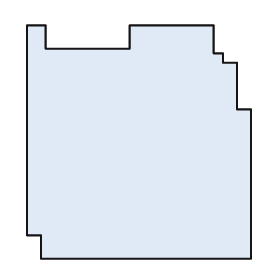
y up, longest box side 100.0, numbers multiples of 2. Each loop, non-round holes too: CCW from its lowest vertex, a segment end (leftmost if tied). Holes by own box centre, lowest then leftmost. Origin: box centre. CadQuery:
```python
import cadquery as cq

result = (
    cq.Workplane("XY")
    .moveTo(-42.0, -50.0)
    .lineTo(48.0, -50.0)
    .lineTo(48.0, 14.0)
    .lineTo(42.0, 14.0)
    .lineTo(42.0, 34.0)
    .lineTo(36.0, 34.0)
    .lineTo(36.0, 38.0)
    .lineTo(32.0, 38.0)
    .lineTo(32.0, 50.0)
    .lineTo(-4.0, 50.0)
    .lineTo(-4.0, 40.0)
    .lineTo(-40.0, 40.0)
    .lineTo(-40.0, 50.0)
    .lineTo(-48.0, 50.0)
    .lineTo(-48.0, -40.0)
    .lineTo(-42.0, -40.0)
    .close()
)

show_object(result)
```